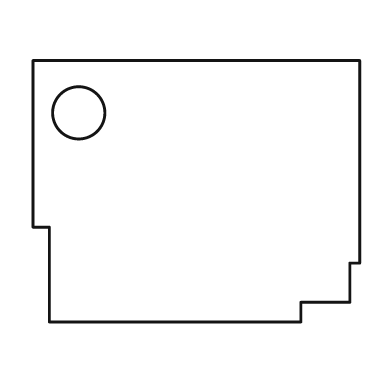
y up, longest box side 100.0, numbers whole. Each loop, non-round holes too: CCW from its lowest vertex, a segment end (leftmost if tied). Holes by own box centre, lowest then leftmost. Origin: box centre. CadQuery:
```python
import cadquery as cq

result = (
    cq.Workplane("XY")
    .moveTo(-45.0, -40.0)
    .lineTo(32.0, -40.0)
    .lineTo(32.0, -34.0)
    .lineTo(47.0, -34.0)
    .lineTo(47.0, -22.0)
    .lineTo(50.0, -22.0)
    .lineTo(50.0, 40.0)
    .lineTo(-50.0, 40.0)
    .lineTo(-50.0, -11.0)
    .lineTo(-45.0, -11.0)
    .close()
    .moveTo(-36.0, 24.0)
    .circle(8.0)
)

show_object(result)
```